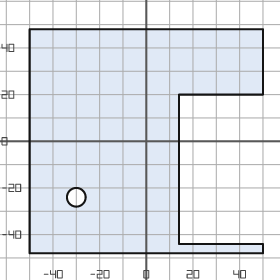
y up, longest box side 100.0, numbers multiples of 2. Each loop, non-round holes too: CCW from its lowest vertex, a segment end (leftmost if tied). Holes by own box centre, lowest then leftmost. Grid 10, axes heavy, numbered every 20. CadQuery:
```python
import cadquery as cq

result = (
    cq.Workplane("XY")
    .moveTo(-50.0, -48.0)
    .lineTo(50.0, -48.0)
    .lineTo(50.0, -44.0)
    .lineTo(14.0, -44.0)
    .lineTo(14.0, 20.0)
    .lineTo(50.0, 20.0)
    .lineTo(50.0, 48.0)
    .lineTo(-50.0, 48.0)
    .close()
    .moveTo(-30.0, -24.0)
    .circle(4.0)
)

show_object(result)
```